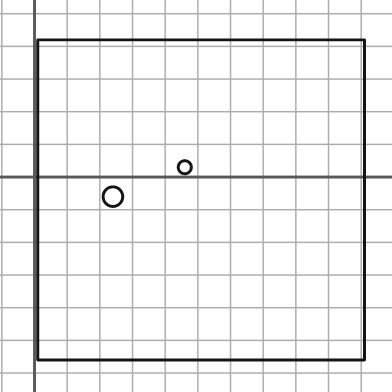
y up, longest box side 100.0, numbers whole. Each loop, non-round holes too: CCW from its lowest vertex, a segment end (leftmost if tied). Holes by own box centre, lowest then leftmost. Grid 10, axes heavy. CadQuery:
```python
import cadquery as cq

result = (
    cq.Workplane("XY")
    .moveTo(1.0, -56.0)
    .lineTo(101.0, -56.0)
    .lineTo(101.0, 42.0)
    .lineTo(1.0, 42.0)
    .close()
    .moveTo(24.0, -6.0)
    .circle(3.0)
    .moveTo(46.0, 3.0)
    .circle(2.0)
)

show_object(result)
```